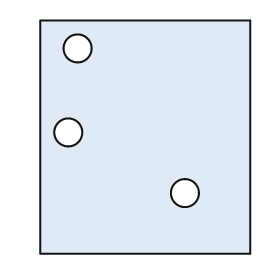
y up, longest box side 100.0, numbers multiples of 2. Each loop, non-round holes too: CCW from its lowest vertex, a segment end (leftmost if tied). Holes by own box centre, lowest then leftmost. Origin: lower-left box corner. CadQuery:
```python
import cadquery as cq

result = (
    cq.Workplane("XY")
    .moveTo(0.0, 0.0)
    .lineTo(90.0, 0.0)
    .lineTo(90.0, 100.0)
    .lineTo(0.0, 100.0)
    .close()
    .moveTo(62.0, 26.0)
    .circle(6.0)
    .moveTo(12.0, 52.0)
    .circle(6.0)
    .moveTo(16.0, 88.0)
    .circle(6.0)
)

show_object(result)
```